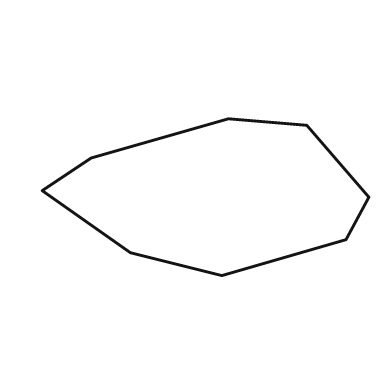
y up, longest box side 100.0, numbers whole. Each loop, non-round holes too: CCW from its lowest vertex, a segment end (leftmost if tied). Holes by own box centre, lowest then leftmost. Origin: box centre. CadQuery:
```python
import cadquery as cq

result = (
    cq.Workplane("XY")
    .moveTo(5.0, -24.0)
    .lineTo(43.0, -13.0)
    .lineTo(50.0, 0.0)
    .lineTo(31.0, 22.0)
    .lineTo(7.0, 24.0)
    .lineTo(-35.0, 12.0)
    .lineTo(-50.0, 2.0)
    .lineTo(-23.0, -17.0)
    .close()
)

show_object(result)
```